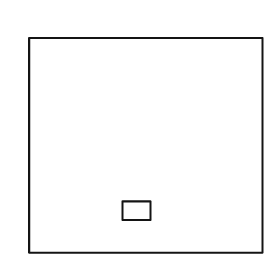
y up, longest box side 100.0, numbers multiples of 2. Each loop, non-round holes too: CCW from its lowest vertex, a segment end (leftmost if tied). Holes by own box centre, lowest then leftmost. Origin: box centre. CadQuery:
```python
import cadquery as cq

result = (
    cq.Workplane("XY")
    .moveTo(-50.0, -46.0)
    .lineTo(50.0, -46.0)
    .lineTo(50.0, 46.0)
    .lineTo(-50.0, 46.0)
    .close()
    .moveTo(-10.0, -32.0)
    .lineTo(2.0, -32.0)
    .lineTo(2.0, -24.0)
    .lineTo(-10.0, -24.0)
    .close()
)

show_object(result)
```